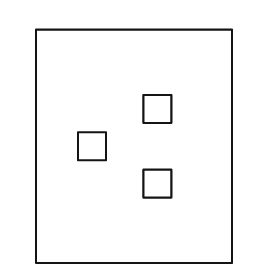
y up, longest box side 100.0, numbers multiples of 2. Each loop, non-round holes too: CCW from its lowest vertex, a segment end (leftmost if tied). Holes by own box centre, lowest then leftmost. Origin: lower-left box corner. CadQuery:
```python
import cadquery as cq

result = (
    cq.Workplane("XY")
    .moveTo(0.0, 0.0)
    .lineTo(84.0, 0.0)
    .lineTo(84.0, 100.0)
    .lineTo(0.0, 100.0)
    .close()
    .moveTo(46.0, 28.0)
    .lineTo(58.0, 28.0)
    .lineTo(58.0, 40.0)
    .lineTo(46.0, 40.0)
    .close()
    .moveTo(18.0, 44.0)
    .lineTo(30.0, 44.0)
    .lineTo(30.0, 56.0)
    .lineTo(18.0, 56.0)
    .close()
    .moveTo(46.0, 60.0)
    .lineTo(58.0, 60.0)
    .lineTo(58.0, 72.0)
    .lineTo(46.0, 72.0)
    .close()
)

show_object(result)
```